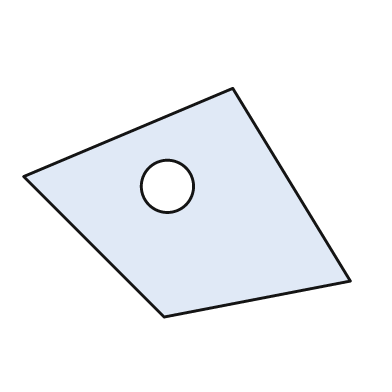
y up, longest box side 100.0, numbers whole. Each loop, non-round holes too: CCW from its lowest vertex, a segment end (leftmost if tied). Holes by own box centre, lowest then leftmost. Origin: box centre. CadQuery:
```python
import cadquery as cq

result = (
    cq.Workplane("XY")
    .moveTo(-7.0, -35.0)
    .lineTo(50.0, -24.0)
    .lineTo(14.0, 35.0)
    .lineTo(-50.0, 8.0)
    .close()
    .moveTo(-6.0, 5.0)
    .circle(8.0)
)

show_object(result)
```